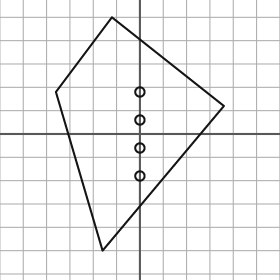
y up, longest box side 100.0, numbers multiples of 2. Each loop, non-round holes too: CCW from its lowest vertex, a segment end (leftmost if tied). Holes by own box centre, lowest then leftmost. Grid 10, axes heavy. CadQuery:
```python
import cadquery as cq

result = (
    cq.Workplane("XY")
    .moveTo(-16.0, -50.0)
    .lineTo(36.0, 12.0)
    .lineTo(-12.0, 50.0)
    .lineTo(-36.0, 18.0)
    .close()
    .moveTo(0.0, -18.0)
    .circle(2.0)
    .moveTo(0.0, -6.0)
    .circle(2.0)
    .moveTo(0.0, 6.0)
    .circle(2.0)
    .moveTo(0.0, 18.0)
    .circle(2.0)
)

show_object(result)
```